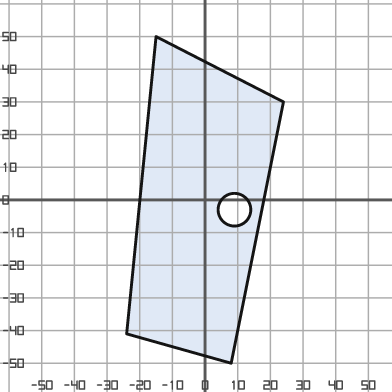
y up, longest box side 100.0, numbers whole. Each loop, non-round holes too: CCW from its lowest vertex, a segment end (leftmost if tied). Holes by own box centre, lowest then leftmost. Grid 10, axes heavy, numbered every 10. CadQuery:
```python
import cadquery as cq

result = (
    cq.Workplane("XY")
    .moveTo(8.0, -50.0)
    .lineTo(24.0, 30.0)
    .lineTo(-15.0, 50.0)
    .lineTo(-24.0, -41.0)
    .close()
    .moveTo(9.0, -3.0)
    .circle(5.0)
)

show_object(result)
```